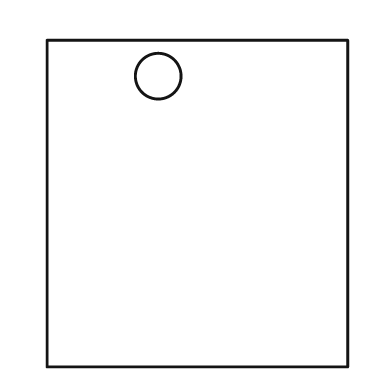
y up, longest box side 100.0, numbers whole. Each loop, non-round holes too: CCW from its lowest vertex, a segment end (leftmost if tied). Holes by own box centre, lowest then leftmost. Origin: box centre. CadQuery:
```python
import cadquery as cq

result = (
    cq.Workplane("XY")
    .moveTo(-46.0, -50.0)
    .lineTo(46.0, -50.0)
    .lineTo(46.0, 50.0)
    .lineTo(-46.0, 50.0)
    .close()
    .moveTo(-12.0, 39.0)
    .circle(7.0)
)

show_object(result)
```